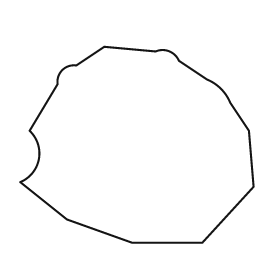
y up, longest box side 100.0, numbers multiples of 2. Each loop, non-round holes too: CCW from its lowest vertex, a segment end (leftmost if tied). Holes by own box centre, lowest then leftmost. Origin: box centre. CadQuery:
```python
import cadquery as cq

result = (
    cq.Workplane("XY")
    .moveTo(-2.0, -42.0)
    .lineTo(28.0, -42.0)
    .lineTo(50.0, -18.0)
    .lineTo(48.0, 6.0)
    .lineTo(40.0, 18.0)
    .threePointArc((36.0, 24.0), (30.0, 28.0))
    .lineTo(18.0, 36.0)
    .threePointArc((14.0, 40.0), (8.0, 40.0))
    .lineTo(-14.0, 42.0)
    .lineTo(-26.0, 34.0)
    .threePointArc((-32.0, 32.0), (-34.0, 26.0))
    .lineTo(-46.0, 6.0)
    .threePointArc((-42.0, -6.0), (-50.0, -16.0))
    .lineTo(-30.0, -32.0)
    .close()
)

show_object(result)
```